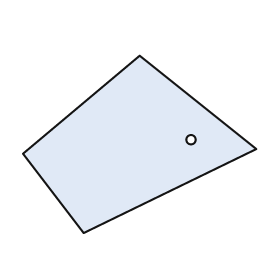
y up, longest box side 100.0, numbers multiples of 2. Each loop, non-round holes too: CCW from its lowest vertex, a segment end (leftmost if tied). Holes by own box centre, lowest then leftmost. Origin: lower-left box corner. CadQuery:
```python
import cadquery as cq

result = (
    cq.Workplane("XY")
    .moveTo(26.0, 0.0)
    .lineTo(100.0, 36.0)
    .lineTo(50.0, 76.0)
    .lineTo(0.0, 34.0)
    .close()
    .moveTo(72.0, 40.0)
    .circle(2.0)
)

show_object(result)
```